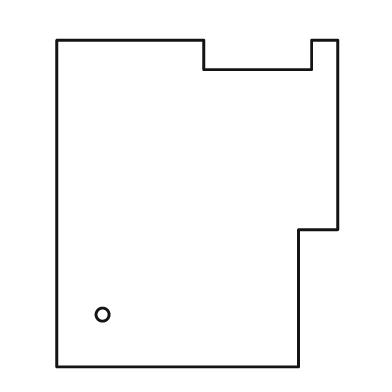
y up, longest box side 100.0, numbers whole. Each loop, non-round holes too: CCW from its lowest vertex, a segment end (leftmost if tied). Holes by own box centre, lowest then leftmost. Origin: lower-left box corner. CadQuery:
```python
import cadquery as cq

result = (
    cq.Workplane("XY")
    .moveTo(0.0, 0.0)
    .lineTo(74.0, 0.0)
    .lineTo(74.0, 42.0)
    .lineTo(86.0, 42.0)
    .lineTo(86.0, 100.0)
    .lineTo(78.0, 100.0)
    .lineTo(78.0, 91.0)
    .lineTo(45.0, 91.0)
    .lineTo(45.0, 100.0)
    .lineTo(0.0, 100.0)
    .close()
    .moveTo(14.0, 16.0)
    .circle(2.0)
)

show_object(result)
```